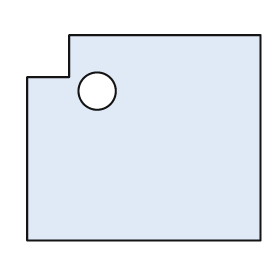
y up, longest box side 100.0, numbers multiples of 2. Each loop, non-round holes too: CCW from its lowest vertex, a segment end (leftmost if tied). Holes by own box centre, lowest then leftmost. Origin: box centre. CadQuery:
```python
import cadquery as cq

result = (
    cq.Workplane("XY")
    .moveTo(-50.0, -44.0)
    .lineTo(50.0, -44.0)
    .lineTo(50.0, 44.0)
    .lineTo(-32.0, 44.0)
    .lineTo(-32.0, 26.0)
    .lineTo(-50.0, 26.0)
    .close()
    .moveTo(-20.0, 20.0)
    .circle(8.0)
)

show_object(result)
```